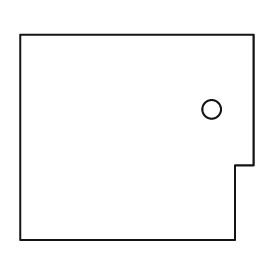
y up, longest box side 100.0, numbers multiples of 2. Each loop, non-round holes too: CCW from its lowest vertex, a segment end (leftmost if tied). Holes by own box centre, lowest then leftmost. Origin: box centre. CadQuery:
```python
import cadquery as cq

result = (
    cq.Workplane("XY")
    .moveTo(-50.0, -44.0)
    .lineTo(42.0, -44.0)
    .lineTo(42.0, -12.0)
    .lineTo(50.0, -12.0)
    .lineTo(50.0, 44.0)
    .lineTo(-50.0, 44.0)
    .close()
    .moveTo(32.0, 12.0)
    .circle(4.0)
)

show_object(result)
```